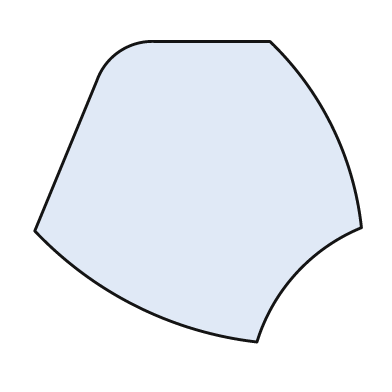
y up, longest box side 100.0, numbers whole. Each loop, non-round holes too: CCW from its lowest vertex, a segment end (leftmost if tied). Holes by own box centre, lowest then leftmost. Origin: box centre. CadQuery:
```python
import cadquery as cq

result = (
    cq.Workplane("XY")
    .moveTo(18.0, -46.0)
    .threePointArc((30.0, -25.0), (50.0, -11.0))
    .threePointArc((41.0, 20.0), (22.0, 46.0))
    .lineTo(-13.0, 46.0)
    .threePointArc((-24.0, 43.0), (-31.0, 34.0))
    .lineTo(-50.0, -12.0)
    .threePointArc((-19.0, -35.0), (18.0, -46.0))
    .close()
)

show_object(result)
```